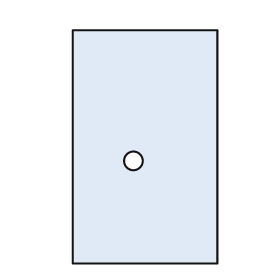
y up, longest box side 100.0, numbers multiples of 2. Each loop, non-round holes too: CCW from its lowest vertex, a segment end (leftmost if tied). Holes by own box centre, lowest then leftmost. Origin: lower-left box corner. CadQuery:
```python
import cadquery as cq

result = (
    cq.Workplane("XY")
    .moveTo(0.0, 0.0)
    .lineTo(62.0, 0.0)
    .lineTo(62.0, 100.0)
    .lineTo(0.0, 100.0)
    .close()
    .moveTo(26.0, 44.0)
    .circle(4.0)
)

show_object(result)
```